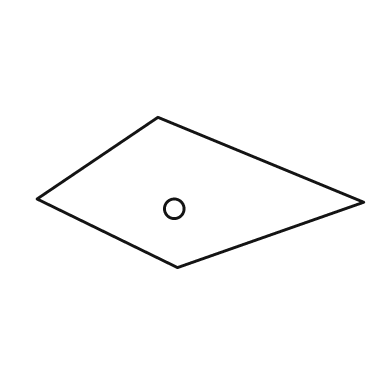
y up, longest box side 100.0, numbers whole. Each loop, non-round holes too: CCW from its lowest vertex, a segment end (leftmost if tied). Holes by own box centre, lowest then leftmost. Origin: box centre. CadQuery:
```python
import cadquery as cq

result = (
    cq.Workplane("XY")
    .moveTo(-7.0, -23.0)
    .lineTo(50.0, -3.0)
    .lineTo(-13.0, 23.0)
    .lineTo(-50.0, -2.0)
    .close()
    .moveTo(-8.0, -5.0)
    .circle(3.0)
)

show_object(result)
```